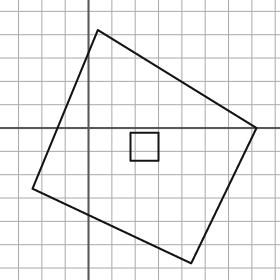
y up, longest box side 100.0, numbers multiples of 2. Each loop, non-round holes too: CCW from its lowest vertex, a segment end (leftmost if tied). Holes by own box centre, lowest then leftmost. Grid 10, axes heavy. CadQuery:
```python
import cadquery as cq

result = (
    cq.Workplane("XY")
    .moveTo(44.0, -58.0)
    .lineTo(72.0, 0.0)
    .lineTo(4.0, 42.0)
    .lineTo(-24.0, -26.0)
    .close()
    .moveTo(18.0, -14.0)
    .lineTo(30.0, -14.0)
    .lineTo(30.0, -2.0)
    .lineTo(18.0, -2.0)
    .close()
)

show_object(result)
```